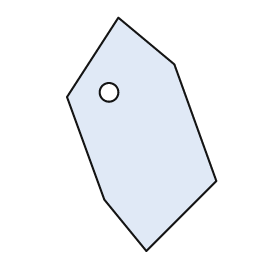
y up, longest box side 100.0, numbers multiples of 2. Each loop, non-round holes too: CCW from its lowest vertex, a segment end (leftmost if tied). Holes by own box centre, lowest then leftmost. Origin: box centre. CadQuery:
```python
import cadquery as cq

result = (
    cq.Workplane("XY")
    .moveTo(2.0, -50.0)
    .lineTo(32.0, -20.0)
    .lineTo(14.0, 30.0)
    .lineTo(-10.0, 50.0)
    .lineTo(-32.0, 16.0)
    .lineTo(-16.0, -28.0)
    .close()
    .moveTo(-14.0, 18.0)
    .circle(4.0)
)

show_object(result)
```